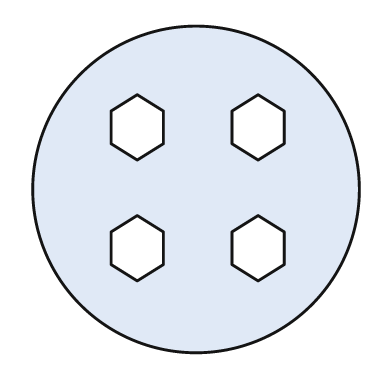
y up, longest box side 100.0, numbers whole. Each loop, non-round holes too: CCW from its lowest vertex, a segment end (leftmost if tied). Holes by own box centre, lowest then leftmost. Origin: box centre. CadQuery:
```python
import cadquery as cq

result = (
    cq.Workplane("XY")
    .moveTo(0.0, 0.0)
    .circle(50.0)
    .moveTo(-18.0, -28.0)
    .lineTo(-10.0, -23.0)
    .lineTo(-10.0, -13.0)
    .lineTo(-18.0, -8.0)
    .lineTo(-26.0, -13.0)
    .lineTo(-26.0, -23.0)
    .close()
    .moveTo(19.0, -28.0)
    .lineTo(27.0, -23.0)
    .lineTo(27.0, -13.0)
    .lineTo(19.0, -8.0)
    .lineTo(11.0, -13.0)
    .lineTo(11.0, -23.0)
    .close()
    .moveTo(-18.0, 9.0)
    .lineTo(-10.0, 14.0)
    .lineTo(-10.0, 24.0)
    .lineTo(-18.0, 29.0)
    .lineTo(-26.0, 24.0)
    .lineTo(-26.0, 14.0)
    .close()
    .moveTo(19.0, 9.0)
    .lineTo(27.0, 14.0)
    .lineTo(27.0, 24.0)
    .lineTo(19.0, 29.0)
    .lineTo(11.0, 24.0)
    .lineTo(11.0, 14.0)
    .close()
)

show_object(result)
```